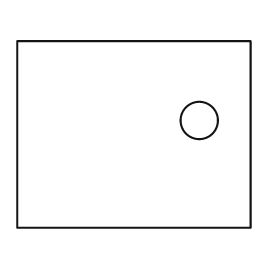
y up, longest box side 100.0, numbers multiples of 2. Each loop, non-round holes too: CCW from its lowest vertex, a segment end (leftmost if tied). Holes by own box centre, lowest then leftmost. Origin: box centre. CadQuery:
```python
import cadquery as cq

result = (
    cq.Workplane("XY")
    .moveTo(-50.0, -40.0)
    .lineTo(50.0, -40.0)
    .lineTo(50.0, 40.0)
    .lineTo(-50.0, 40.0)
    .close()
    .moveTo(28.0, 6.0)
    .circle(8.0)
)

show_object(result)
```